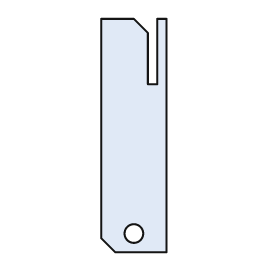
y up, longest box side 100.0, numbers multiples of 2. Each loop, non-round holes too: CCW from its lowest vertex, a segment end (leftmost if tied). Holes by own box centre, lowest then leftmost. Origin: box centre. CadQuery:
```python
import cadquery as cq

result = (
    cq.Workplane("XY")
    .moveTo(-8.0, -50.0)
    .lineTo(14.0, -50.0)
    .lineTo(14.0, 50.0)
    .lineTo(10.0, 50.0)
    .lineTo(10.0, 22.0)
    .lineTo(6.0, 22.0)
    .lineTo(6.0, 44.0)
    .lineTo(0.0, 50.0)
    .lineTo(-14.0, 50.0)
    .lineTo(-14.0, -44.0)
    .close()
    .moveTo(0.0, -42.0)
    .circle(4.0)
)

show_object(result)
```